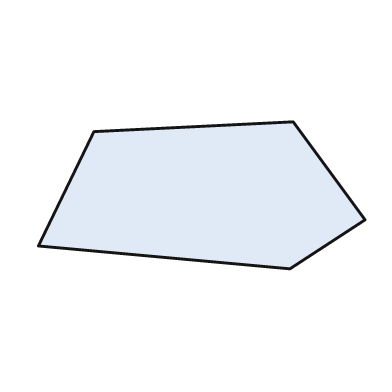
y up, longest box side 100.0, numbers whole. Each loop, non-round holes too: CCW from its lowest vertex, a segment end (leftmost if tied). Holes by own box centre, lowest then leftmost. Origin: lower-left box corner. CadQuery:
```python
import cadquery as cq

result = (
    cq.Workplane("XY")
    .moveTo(77.0, 0.0)
    .lineTo(100.0, 15.0)
    .lineTo(78.0, 45.0)
    .lineTo(17.0, 42.0)
    .lineTo(0.0, 7.0)
    .close()
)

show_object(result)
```